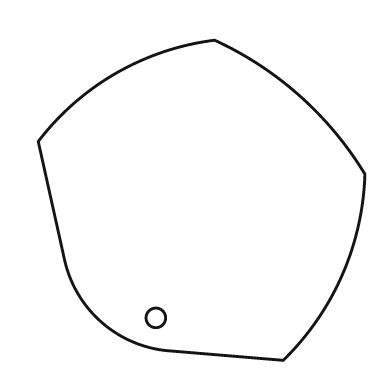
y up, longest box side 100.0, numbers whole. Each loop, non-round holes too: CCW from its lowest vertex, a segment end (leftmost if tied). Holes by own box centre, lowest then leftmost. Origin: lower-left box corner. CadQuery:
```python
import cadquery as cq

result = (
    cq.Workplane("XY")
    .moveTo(75.0, 0.0)
    .threePointArc((93.0, 26.0), (100.0, 57.0))
    .threePointArc((80.0, 81.0), (54.0, 98.0))
    .threePointArc((24.0, 88.0), (0.0, 67.0))
    .lineTo(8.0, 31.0)
    .threePointArc((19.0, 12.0), (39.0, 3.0))
    .close()
    .moveTo(36.0, 13.0)
    .circle(3.0)
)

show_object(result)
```